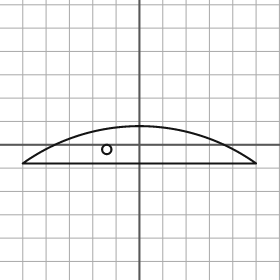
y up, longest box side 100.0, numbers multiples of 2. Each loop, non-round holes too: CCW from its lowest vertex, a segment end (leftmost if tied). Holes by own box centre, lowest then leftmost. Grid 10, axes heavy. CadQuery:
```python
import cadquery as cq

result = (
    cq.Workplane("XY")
    .moveTo(-50.0, -8.0)
    .lineTo(50.0, -8.0)
    .threePointArc((0.0, 8.0), (-50.0, -8.0))
    .close()
    .moveTo(-14.0, -2.0)
    .circle(2.0)
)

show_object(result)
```